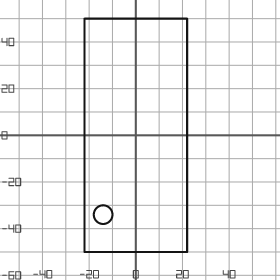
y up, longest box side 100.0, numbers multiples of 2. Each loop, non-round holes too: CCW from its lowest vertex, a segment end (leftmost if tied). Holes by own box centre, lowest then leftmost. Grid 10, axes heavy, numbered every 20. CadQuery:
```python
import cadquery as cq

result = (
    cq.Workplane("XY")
    .moveTo(-22.0, -50.0)
    .lineTo(22.0, -50.0)
    .lineTo(22.0, 50.0)
    .lineTo(-22.0, 50.0)
    .close()
    .moveTo(-14.0, -34.0)
    .circle(4.0)
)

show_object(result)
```